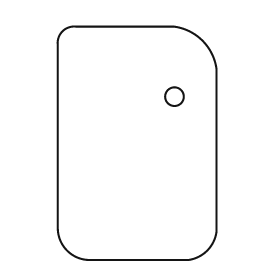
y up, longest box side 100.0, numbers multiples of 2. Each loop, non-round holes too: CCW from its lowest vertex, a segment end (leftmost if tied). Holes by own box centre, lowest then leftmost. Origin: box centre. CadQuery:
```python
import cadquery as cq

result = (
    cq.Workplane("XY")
    .moveTo(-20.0, -50.0)
    .lineTo(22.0, -50.0)
    .threePointArc((30.0, -46.0), (34.0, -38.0))
    .lineTo(34.0, 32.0)
    .threePointArc((28.0, 44.0), (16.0, 50.0))
    .lineTo(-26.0, 50.0)
    .threePointArc((-32.0, 48.0), (-34.0, 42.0))
    .lineTo(-34.0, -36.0)
    .threePointArc((-30.0, -46.0), (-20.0, -50.0))
    .close()
    .moveTo(16.0, 20.0)
    .circle(4.0)
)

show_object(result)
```